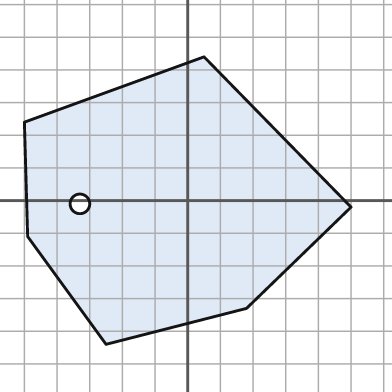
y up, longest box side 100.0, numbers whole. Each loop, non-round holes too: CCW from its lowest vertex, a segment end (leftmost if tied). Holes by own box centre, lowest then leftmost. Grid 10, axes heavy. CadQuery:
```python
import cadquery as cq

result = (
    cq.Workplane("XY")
    .moveTo(-25.0, -44.0)
    .lineTo(18.0, -33.0)
    .lineTo(50.0, -2.0)
    .lineTo(5.0, 44.0)
    .lineTo(-50.0, 24.0)
    .lineTo(-49.0, -11.0)
    .close()
    .moveTo(-33.0, -1.0)
    .circle(3.0)
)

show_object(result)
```